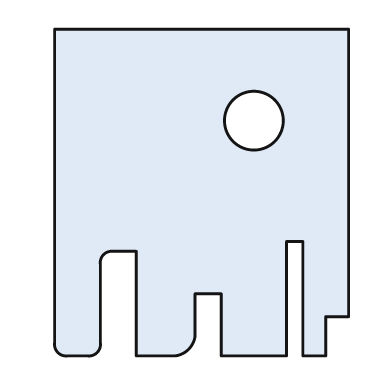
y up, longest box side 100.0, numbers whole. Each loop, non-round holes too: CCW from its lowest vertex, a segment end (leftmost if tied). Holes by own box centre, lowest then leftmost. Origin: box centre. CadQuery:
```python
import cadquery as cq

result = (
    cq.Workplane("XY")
    .moveTo(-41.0, -50.0)
    .lineTo(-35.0, -50.0)
    .threePointArc((-32.0, -49.0), (-31.0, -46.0))
    .lineTo(-31.0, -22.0)
    .threePointArc((-30.0, -19.0), (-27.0, -18.0))
    .lineTo(-20.0, -18.0)
    .lineTo(-20.0, -50.0)
    .lineTo(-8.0, -50.0)
    .threePointArc((-4.0, -48.0), (-2.0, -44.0))
    .lineTo(-2.0, -31.0)
    .lineTo(6.0, -31.0)
    .lineTo(6.0, -50.0)
    .lineTo(26.0, -50.0)
    .lineTo(26.0, -15.0)
    .lineTo(31.0, -15.0)
    .lineTo(31.0, -50.0)
    .lineTo(38.0, -50.0)
    .lineTo(38.0, -38.0)
    .lineTo(45.0, -38.0)
    .lineTo(45.0, 50.0)
    .lineTo(-45.0, 50.0)
    .lineTo(-45.0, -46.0)
    .threePointArc((-44.0, -49.0), (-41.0, -50.0))
    .close()
    .moveTo(16.0, 22.0)
    .circle(9.0)
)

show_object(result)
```